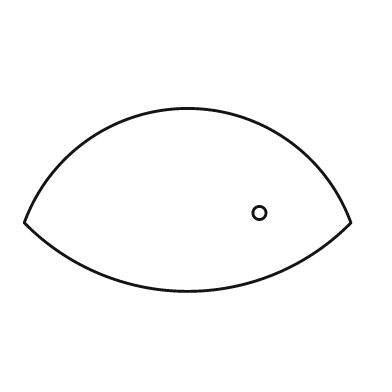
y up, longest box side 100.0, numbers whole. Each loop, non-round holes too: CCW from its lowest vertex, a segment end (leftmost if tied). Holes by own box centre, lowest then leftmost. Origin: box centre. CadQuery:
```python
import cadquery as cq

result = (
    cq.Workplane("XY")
    .moveTo(-50.0, -7.0)
    .threePointArc((0.0, -28.0), (50.0, -7.0))
    .threePointArc((0.0, 28.0), (-50.0, -7.0))
    .close()
    .moveTo(22.0, -4.0)
    .circle(2.0)
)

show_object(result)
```